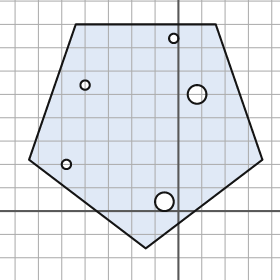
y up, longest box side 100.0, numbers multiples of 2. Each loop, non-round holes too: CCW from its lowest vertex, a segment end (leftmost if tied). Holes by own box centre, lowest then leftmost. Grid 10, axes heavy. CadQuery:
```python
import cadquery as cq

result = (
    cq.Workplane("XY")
    .moveTo(-14.0, -16.0)
    .lineTo(36.0, 22.0)
    .lineTo(16.0, 80.0)
    .lineTo(-44.0, 80.0)
    .lineTo(-64.0, 22.0)
    .close()
    .moveTo(-6.0, 4.0)
    .circle(4.0)
    .moveTo(-48.0, 20.0)
    .circle(2.0)
    .moveTo(8.0, 50.0)
    .circle(4.0)
    .moveTo(-40.0, 54.0)
    .circle(2.0)
    .moveTo(-2.0, 74.0)
    .circle(2.0)
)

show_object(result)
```